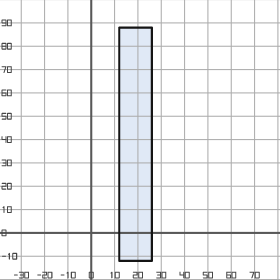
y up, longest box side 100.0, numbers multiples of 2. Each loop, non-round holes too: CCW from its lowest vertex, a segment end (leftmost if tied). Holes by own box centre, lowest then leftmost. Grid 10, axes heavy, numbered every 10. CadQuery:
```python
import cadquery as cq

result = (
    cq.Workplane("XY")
    .moveTo(12.0, -12.0)
    .lineTo(26.0, -12.0)
    .lineTo(26.0, 88.0)
    .lineTo(12.0, 88.0)
    .close()
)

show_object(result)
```